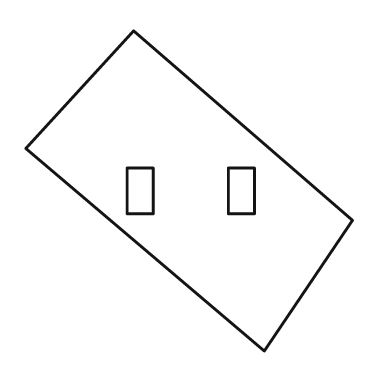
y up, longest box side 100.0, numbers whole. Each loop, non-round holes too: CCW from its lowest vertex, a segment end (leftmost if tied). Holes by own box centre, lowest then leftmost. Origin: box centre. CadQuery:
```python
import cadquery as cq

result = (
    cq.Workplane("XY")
    .moveTo(23.0, -49.0)
    .lineTo(50.0, -9.0)
    .lineTo(-17.0, 49.0)
    .lineTo(-50.0, 13.0)
    .close()
    .moveTo(-19.0, -7.0)
    .lineTo(-11.0, -7.0)
    .lineTo(-11.0, 7.0)
    .lineTo(-19.0, 7.0)
    .close()
    .moveTo(12.0, -7.0)
    .lineTo(20.0, -7.0)
    .lineTo(20.0, 7.0)
    .lineTo(12.0, 7.0)
    .close()
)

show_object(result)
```